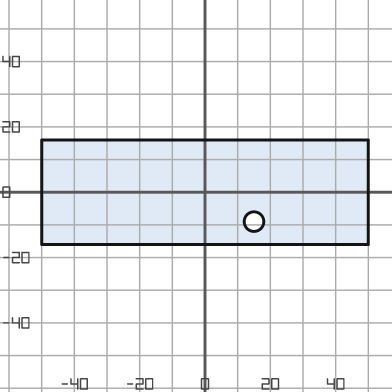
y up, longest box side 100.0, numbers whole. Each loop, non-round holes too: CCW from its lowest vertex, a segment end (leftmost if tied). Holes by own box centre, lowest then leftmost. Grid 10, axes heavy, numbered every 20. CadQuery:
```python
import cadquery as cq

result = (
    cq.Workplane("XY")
    .moveTo(-50.0, -16.0)
    .lineTo(50.0, -16.0)
    .lineTo(50.0, 16.0)
    .lineTo(-50.0, 16.0)
    .close()
    .moveTo(15.0, -9.0)
    .circle(3.0)
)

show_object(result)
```